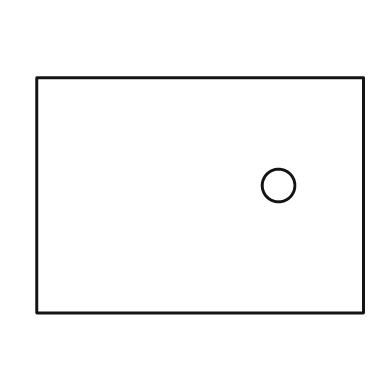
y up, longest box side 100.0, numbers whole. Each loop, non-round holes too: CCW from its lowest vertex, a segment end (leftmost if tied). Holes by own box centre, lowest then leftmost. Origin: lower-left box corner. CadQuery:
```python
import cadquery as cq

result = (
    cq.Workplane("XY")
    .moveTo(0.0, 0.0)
    .lineTo(100.0, 0.0)
    .lineTo(100.0, 72.0)
    .lineTo(0.0, 72.0)
    .close()
    .moveTo(74.0, 39.0)
    .circle(5.0)
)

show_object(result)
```